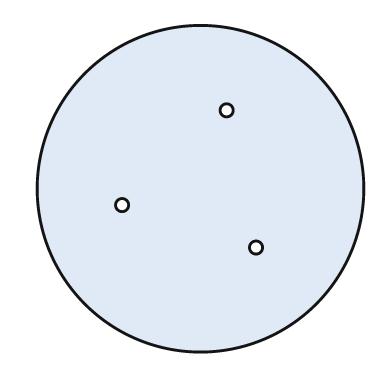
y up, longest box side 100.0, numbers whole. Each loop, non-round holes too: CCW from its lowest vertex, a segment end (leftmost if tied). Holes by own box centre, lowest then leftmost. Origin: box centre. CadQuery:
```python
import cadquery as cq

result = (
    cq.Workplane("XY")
    .moveTo(0.0, 0.0)
    .circle(50.0)
    .moveTo(17.0, -18.0)
    .circle(2.0)
    .moveTo(-24.0, -5.0)
    .circle(2.0)
    .moveTo(8.0, 24.0)
    .circle(2.0)
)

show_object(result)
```